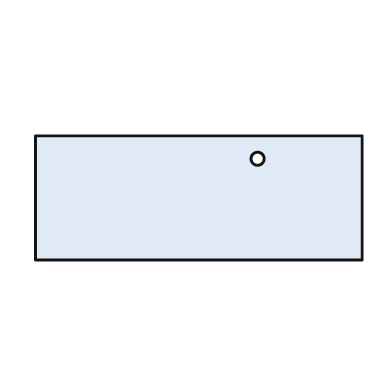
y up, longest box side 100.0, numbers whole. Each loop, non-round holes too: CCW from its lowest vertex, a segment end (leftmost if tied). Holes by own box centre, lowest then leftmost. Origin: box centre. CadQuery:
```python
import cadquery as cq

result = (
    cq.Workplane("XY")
    .moveTo(-50.0, -19.0)
    .lineTo(50.0, -19.0)
    .lineTo(50.0, 19.0)
    .lineTo(-50.0, 19.0)
    .close()
    .moveTo(18.0, 12.0)
    .circle(2.0)
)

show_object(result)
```